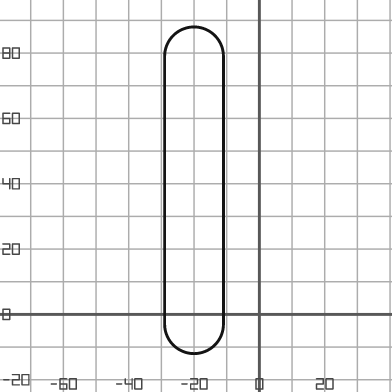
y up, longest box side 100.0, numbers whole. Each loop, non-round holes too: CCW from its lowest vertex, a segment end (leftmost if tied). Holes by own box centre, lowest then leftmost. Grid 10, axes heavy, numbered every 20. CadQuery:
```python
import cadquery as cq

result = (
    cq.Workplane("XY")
    .moveTo(-29.0, -3.0)
    .threePointArc((-20.0, -12.0), (-11.0, -3.0))
    .lineTo(-11.0, 79.0)
    .threePointArc((-20.0, 88.0), (-29.0, 79.0))
    .close()
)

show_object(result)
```